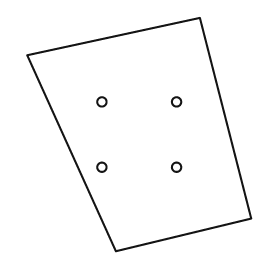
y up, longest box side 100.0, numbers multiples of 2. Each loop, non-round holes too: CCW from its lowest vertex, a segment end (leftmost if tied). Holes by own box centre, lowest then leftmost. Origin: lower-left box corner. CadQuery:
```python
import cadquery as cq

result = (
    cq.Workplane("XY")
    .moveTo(38.0, 0.0)
    .lineTo(96.0, 14.0)
    .lineTo(74.0, 100.0)
    .lineTo(0.0, 84.0)
    .close()
    .moveTo(32.0, 36.0)
    .circle(2.0)
    .moveTo(64.0, 36.0)
    .circle(2.0)
    .moveTo(32.0, 64.0)
    .circle(2.0)
    .moveTo(64.0, 64.0)
    .circle(2.0)
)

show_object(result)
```